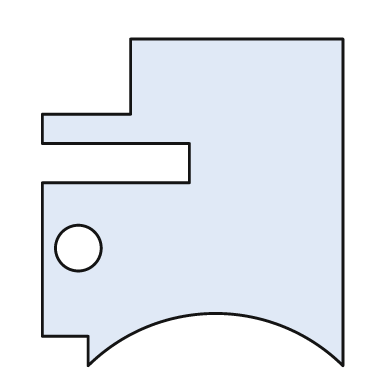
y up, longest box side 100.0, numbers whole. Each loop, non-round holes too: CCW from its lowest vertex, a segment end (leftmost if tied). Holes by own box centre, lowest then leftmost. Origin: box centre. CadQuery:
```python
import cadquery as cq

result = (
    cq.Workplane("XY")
    .moveTo(-32.0, -50.0)
    .threePointArc((7.0, -34.0), (46.0, -50.0))
    .lineTo(46.0, 50.0)
    .lineTo(-19.0, 50.0)
    .lineTo(-19.0, 27.0)
    .lineTo(-46.0, 27.0)
    .lineTo(-46.0, 18.0)
    .lineTo(-1.0, 18.0)
    .lineTo(-1.0, 6.0)
    .lineTo(-46.0, 6.0)
    .lineTo(-46.0, -41.0)
    .lineTo(-32.0, -41.0)
    .close()
    .moveTo(-35.0, -14.0)
    .circle(7.0)
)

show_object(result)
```